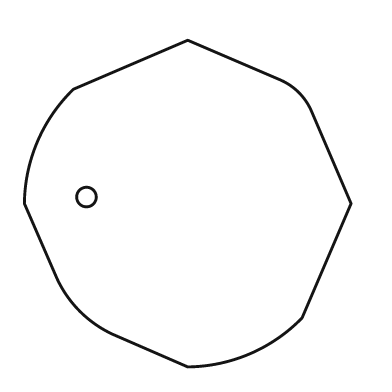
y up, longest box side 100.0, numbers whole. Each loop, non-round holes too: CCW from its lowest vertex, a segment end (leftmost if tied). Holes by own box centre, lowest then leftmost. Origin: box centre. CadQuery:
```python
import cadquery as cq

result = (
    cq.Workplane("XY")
    .moveTo(0.0, -50.0)
    .threePointArc((19.0, -46.0), (35.0, -35.0))
    .lineTo(50.0, 0.0)
    .lineTo(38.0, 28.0)
    .threePointArc((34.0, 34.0), (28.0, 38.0))
    .lineTo(0.0, 50.0)
    .lineTo(-35.0, 35.0)
    .threePointArc((-46.0, 19.0), (-50.0, 0.0))
    .lineTo(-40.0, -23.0)
    .threePointArc((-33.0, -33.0), (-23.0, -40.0))
    .close()
    .moveTo(-31.0, 2.0)
    .circle(3.0)
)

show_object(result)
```